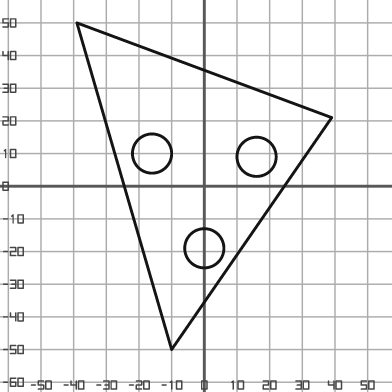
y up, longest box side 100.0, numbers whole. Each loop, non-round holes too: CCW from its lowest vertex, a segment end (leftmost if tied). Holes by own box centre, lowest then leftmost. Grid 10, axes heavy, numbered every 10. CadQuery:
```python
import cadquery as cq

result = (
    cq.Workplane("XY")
    .moveTo(-10.0, -50.0)
    .lineTo(39.0, 21.0)
    .lineTo(-39.0, 50.0)
    .close()
    .moveTo(0.0, -19.0)
    .circle(6.0)
    .moveTo(16.0, 9.0)
    .circle(6.0)
    .moveTo(-16.0, 10.0)
    .circle(6.0)
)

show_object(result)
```